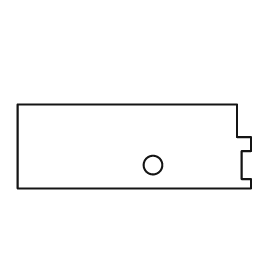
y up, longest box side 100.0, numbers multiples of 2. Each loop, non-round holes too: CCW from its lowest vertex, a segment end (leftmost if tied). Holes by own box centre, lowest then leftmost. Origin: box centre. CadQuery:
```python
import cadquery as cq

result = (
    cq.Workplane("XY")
    .moveTo(-50.0, -18.0)
    .lineTo(50.0, -18.0)
    .lineTo(50.0, -14.0)
    .lineTo(46.0, -14.0)
    .lineTo(46.0, -2.0)
    .lineTo(50.0, -2.0)
    .lineTo(50.0, 4.0)
    .lineTo(44.0, 4.0)
    .lineTo(44.0, 18.0)
    .lineTo(-50.0, 18.0)
    .close()
    .moveTo(8.0, -8.0)
    .circle(4.0)
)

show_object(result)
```